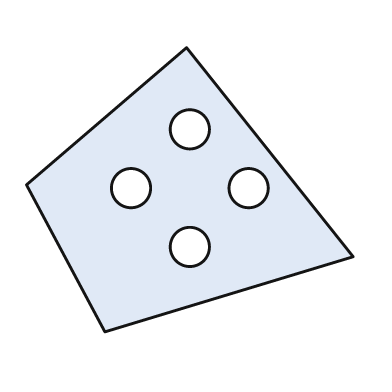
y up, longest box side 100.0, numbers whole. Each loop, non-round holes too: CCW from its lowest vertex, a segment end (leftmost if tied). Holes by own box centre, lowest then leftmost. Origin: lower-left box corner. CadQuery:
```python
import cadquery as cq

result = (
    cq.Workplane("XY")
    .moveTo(24.0, 0.0)
    .lineTo(100.0, 23.0)
    .lineTo(49.0, 87.0)
    .lineTo(0.0, 45.0)
    .close()
    .moveTo(50.0, 26.0)
    .circle(6.0)
    .moveTo(32.0, 44.0)
    .circle(6.0)
    .moveTo(68.0, 44.0)
    .circle(6.0)
    .moveTo(50.0, 62.0)
    .circle(6.0)
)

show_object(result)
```